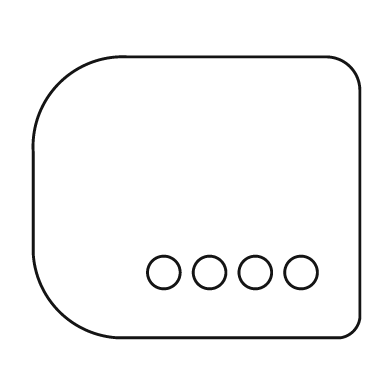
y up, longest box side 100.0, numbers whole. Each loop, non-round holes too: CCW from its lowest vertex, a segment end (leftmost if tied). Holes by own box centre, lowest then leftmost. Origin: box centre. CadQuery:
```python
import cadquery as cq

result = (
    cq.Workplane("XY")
    .moveTo(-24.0, -43.0)
    .lineTo(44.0, -43.0)
    .threePointArc((48.0, -41.0), (50.0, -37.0))
    .lineTo(50.0, 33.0)
    .threePointArc((47.0, 40.0), (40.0, 43.0))
    .lineTo(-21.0, 43.0)
    .threePointArc((-42.0, 35.0), (-50.0, 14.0))
    .lineTo(-50.0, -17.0)
    .threePointArc((-42.0, -35.0), (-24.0, -43.0))
    .close()
    .moveTo(-10.0, -23.0)
    .circle(5.0)
    .moveTo(4.0, -23.0)
    .circle(5.0)
    .moveTo(18.0, -23.0)
    .circle(5.0)
    .moveTo(32.0, -23.0)
    .circle(5.0)
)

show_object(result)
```